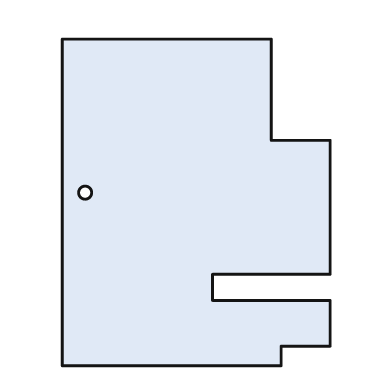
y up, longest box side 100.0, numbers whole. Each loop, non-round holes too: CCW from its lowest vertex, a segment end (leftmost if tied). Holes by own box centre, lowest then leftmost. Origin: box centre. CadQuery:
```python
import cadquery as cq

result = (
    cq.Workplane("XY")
    .moveTo(-41.0, -50.0)
    .lineTo(26.0, -50.0)
    .lineTo(26.0, -44.0)
    .lineTo(41.0, -44.0)
    .lineTo(41.0, -30.0)
    .lineTo(5.0, -30.0)
    .lineTo(5.0, -22.0)
    .lineTo(41.0, -22.0)
    .lineTo(41.0, 19.0)
    .lineTo(23.0, 19.0)
    .lineTo(23.0, 50.0)
    .lineTo(-41.0, 50.0)
    .close()
    .moveTo(-34.0, 3.0)
    .circle(2.0)
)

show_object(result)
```